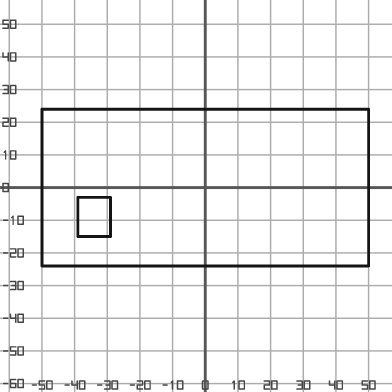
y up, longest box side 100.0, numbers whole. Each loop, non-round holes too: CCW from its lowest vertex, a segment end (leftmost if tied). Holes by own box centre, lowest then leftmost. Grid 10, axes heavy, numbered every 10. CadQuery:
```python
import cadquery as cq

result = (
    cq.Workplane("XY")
    .moveTo(-50.0, -24.0)
    .lineTo(50.0, -24.0)
    .lineTo(50.0, 24.0)
    .lineTo(-50.0, 24.0)
    .close()
    .moveTo(-39.0, -15.0)
    .lineTo(-29.0, -15.0)
    .lineTo(-29.0, -3.0)
    .lineTo(-39.0, -3.0)
    .close()
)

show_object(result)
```